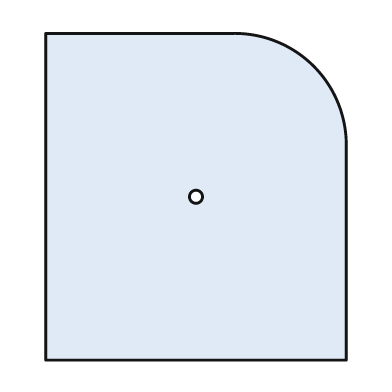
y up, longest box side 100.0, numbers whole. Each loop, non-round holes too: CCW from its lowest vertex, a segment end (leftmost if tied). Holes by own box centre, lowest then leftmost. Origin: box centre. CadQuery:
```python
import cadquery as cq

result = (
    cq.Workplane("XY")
    .moveTo(-46.0, -50.0)
    .lineTo(46.0, -50.0)
    .lineTo(46.0, 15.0)
    .threePointArc((36.0, 40.0), (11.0, 50.0))
    .lineTo(-46.0, 50.0)
    .close()
    .moveTo(0.0, 0.0)
    .circle(2.0)
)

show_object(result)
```